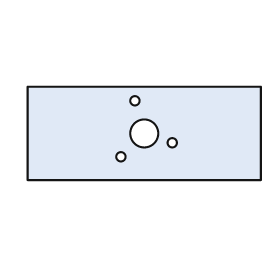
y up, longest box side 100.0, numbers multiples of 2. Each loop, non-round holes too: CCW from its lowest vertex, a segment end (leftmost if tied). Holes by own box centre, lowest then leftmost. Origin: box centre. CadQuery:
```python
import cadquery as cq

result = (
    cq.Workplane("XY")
    .moveTo(-50.0, -20.0)
    .lineTo(50.0, -20.0)
    .lineTo(50.0, 20.0)
    .lineTo(-50.0, 20.0)
    .close()
    .moveTo(-10.0, -10.0)
    .circle(2.0)
    .moveTo(12.0, -4.0)
    .circle(2.0)
    .moveTo(0.0, 0.0)
    .circle(6.0)
    .moveTo(-4.0, 14.0)
    .circle(2.0)
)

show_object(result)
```